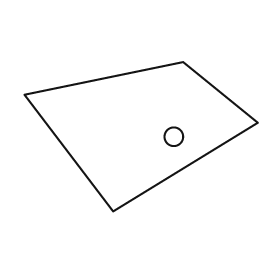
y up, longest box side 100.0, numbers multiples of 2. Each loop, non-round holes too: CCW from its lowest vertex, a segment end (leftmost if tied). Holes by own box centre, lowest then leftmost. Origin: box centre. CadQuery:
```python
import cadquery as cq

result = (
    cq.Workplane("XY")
    .moveTo(-12.0, -32.0)
    .lineTo(50.0, 6.0)
    .lineTo(18.0, 32.0)
    .lineTo(-50.0, 18.0)
    .close()
    .moveTo(14.0, 0.0)
    .circle(4.0)
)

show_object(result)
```